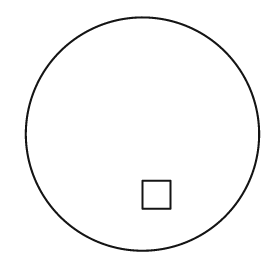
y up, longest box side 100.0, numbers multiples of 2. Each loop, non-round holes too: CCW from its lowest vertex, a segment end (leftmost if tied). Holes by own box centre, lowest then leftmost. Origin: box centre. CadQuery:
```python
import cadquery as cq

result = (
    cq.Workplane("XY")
    .moveTo(0.0, 0.0)
    .circle(50.0)
    .moveTo(0.0, -32.0)
    .lineTo(12.0, -32.0)
    .lineTo(12.0, -20.0)
    .lineTo(0.0, -20.0)
    .close()
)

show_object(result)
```